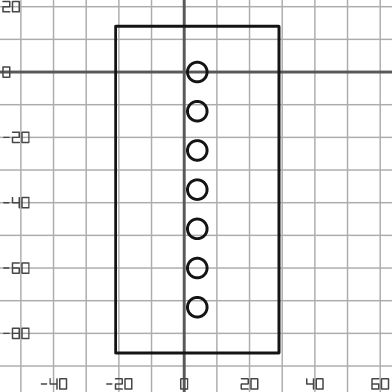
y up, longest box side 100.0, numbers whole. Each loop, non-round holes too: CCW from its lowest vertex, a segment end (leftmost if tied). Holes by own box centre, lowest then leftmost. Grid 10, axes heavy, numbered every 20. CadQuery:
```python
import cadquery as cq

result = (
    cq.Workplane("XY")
    .moveTo(-21.0, -86.0)
    .lineTo(29.0, -86.0)
    .lineTo(29.0, 14.0)
    .lineTo(-21.0, 14.0)
    .close()
    .moveTo(4.0, -72.0)
    .circle(3.0)
    .moveTo(4.0, -60.0)
    .circle(3.0)
    .moveTo(4.0, -48.0)
    .circle(3.0)
    .moveTo(4.0, -36.0)
    .circle(3.0)
    .moveTo(4.0, -24.0)
    .circle(3.0)
    .moveTo(4.0, -12.0)
    .circle(3.0)
    .moveTo(4.0, 0.0)
    .circle(3.0)
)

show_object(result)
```